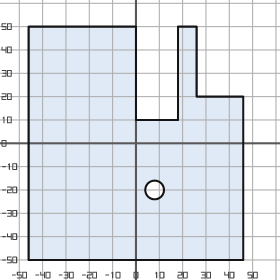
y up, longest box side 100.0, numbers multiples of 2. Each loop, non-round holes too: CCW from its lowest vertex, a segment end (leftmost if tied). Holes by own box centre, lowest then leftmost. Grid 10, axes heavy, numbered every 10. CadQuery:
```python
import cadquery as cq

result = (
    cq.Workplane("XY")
    .moveTo(-46.0, -50.0)
    .lineTo(46.0, -50.0)
    .lineTo(46.0, 20.0)
    .lineTo(26.0, 20.0)
    .lineTo(26.0, 50.0)
    .lineTo(18.0, 50.0)
    .lineTo(18.0, 10.0)
    .lineTo(0.0, 10.0)
    .lineTo(0.0, 50.0)
    .lineTo(-46.0, 50.0)
    .close()
    .moveTo(8.0, -20.0)
    .circle(4.0)
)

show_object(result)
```